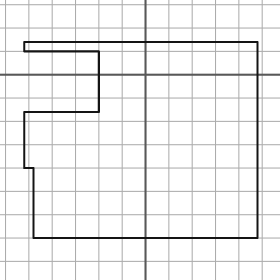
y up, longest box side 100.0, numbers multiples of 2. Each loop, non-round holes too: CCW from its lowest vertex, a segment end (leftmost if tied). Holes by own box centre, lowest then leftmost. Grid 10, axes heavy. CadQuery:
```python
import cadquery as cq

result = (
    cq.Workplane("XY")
    .moveTo(-48.0, -70.0)
    .lineTo(48.0, -70.0)
    .lineTo(48.0, 14.0)
    .lineTo(-52.0, 14.0)
    .lineTo(-52.0, 10.0)
    .lineTo(-20.0, 10.0)
    .lineTo(-20.0, -16.0)
    .lineTo(-52.0, -16.0)
    .lineTo(-52.0, -40.0)
    .lineTo(-48.0, -40.0)
    .close()
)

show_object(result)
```